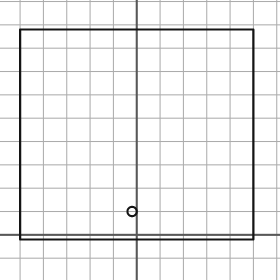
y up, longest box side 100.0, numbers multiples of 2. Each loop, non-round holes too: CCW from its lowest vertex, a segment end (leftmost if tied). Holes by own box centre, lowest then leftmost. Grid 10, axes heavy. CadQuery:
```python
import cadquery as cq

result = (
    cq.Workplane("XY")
    .moveTo(-50.0, -2.0)
    .lineTo(50.0, -2.0)
    .lineTo(50.0, 88.0)
    .lineTo(-50.0, 88.0)
    .close()
    .moveTo(-2.0, 10.0)
    .circle(2.0)
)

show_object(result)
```